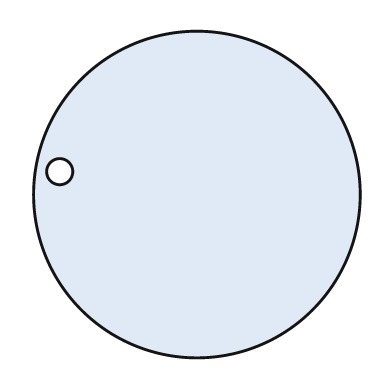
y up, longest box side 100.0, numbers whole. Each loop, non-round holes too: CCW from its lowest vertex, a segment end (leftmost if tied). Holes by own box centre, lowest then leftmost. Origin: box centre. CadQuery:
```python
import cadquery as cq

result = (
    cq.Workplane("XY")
    .moveTo(0.0, 0.0)
    .circle(50.0)
    .moveTo(-42.0, 7.0)
    .circle(4.0)
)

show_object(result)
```